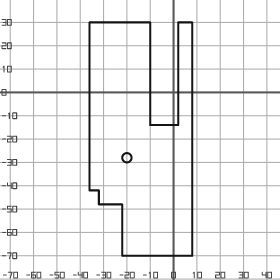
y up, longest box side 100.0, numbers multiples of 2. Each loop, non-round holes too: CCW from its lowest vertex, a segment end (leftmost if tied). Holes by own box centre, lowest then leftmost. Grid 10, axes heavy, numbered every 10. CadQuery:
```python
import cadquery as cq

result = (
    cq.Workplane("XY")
    .moveTo(-22.0, -70.0)
    .lineTo(8.0, -70.0)
    .lineTo(8.0, 30.0)
    .lineTo(2.0, 30.0)
    .lineTo(2.0, -14.0)
    .lineTo(-10.0, -14.0)
    .lineTo(-10.0, 30.0)
    .lineTo(-36.0, 30.0)
    .lineTo(-36.0, -42.0)
    .lineTo(-32.0, -42.0)
    .lineTo(-32.0, -48.0)
    .lineTo(-22.0, -48.0)
    .close()
    .moveTo(-20.0, -28.0)
    .circle(2.0)
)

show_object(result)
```